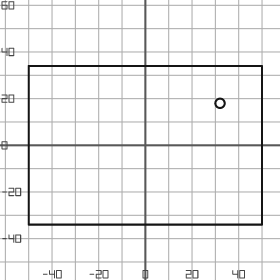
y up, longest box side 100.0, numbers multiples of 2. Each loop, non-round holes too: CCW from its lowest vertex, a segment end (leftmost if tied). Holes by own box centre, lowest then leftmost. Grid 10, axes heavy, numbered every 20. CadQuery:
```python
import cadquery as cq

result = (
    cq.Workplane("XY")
    .moveTo(-50.0, -34.0)
    .lineTo(50.0, -34.0)
    .lineTo(50.0, 34.0)
    .lineTo(-50.0, 34.0)
    .close()
    .moveTo(32.0, 18.0)
    .circle(2.0)
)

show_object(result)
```